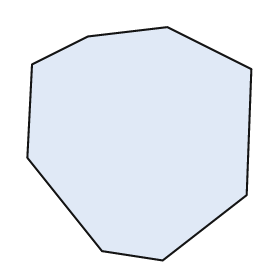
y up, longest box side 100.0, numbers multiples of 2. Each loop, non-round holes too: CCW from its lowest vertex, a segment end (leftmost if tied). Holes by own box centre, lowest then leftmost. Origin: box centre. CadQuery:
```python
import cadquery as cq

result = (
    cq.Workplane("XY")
    .moveTo(10.0, -50.0)
    .lineTo(46.0, -22.0)
    .lineTo(48.0, 32.0)
    .lineTo(12.0, 50.0)
    .lineTo(-22.0, 46.0)
    .lineTo(-46.0, 34.0)
    .lineTo(-48.0, -6.0)
    .lineTo(-16.0, -46.0)
    .close()
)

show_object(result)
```